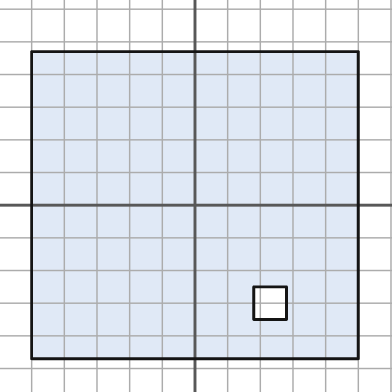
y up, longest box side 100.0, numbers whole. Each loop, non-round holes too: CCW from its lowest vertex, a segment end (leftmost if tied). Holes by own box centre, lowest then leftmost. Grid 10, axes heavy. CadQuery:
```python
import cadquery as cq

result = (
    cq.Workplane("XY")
    .moveTo(-50.0, -47.0)
    .lineTo(50.0, -47.0)
    .lineTo(50.0, 47.0)
    .lineTo(-50.0, 47.0)
    .close()
    .moveTo(18.0, -35.0)
    .lineTo(28.0, -35.0)
    .lineTo(28.0, -25.0)
    .lineTo(18.0, -25.0)
    .close()
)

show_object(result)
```